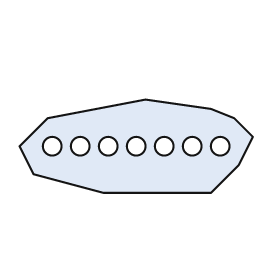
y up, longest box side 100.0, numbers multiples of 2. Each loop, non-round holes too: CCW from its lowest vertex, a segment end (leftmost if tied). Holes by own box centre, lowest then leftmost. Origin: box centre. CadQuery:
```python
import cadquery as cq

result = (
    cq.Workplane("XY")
    .moveTo(-14.0, -20.0)
    .lineTo(32.0, -20.0)
    .lineTo(44.0, -8.0)
    .lineTo(50.0, 4.0)
    .lineTo(42.0, 12.0)
    .lineTo(32.0, 16.0)
    .lineTo(4.0, 20.0)
    .lineTo(-38.0, 12.0)
    .lineTo(-50.0, 0.0)
    .lineTo(-44.0, -12.0)
    .close()
    .moveTo(-36.0, 0.0)
    .circle(4.0)
    .moveTo(-24.0, 0.0)
    .circle(4.0)
    .moveTo(-12.0, 0.0)
    .circle(4.0)
    .moveTo(0.0, 0.0)
    .circle(4.0)
    .moveTo(12.0, 0.0)
    .circle(4.0)
    .moveTo(24.0, 0.0)
    .circle(4.0)
    .moveTo(36.0, 0.0)
    .circle(4.0)
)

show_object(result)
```